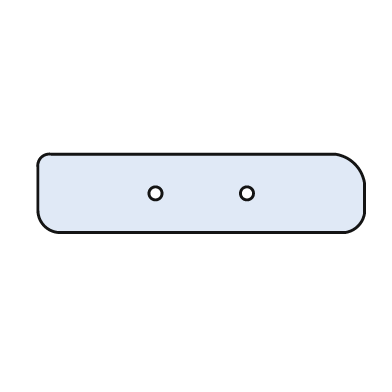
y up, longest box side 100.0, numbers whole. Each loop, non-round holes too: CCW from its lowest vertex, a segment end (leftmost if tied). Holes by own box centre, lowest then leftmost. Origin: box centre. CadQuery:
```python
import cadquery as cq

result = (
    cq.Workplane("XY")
    .moveTo(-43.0, -12.0)
    .lineTo(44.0, -12.0)
    .threePointArc((48.0, -10.0), (50.0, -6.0))
    .lineTo(50.0, 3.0)
    .threePointArc((47.0, 9.0), (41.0, 12.0))
    .lineTo(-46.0, 12.0)
    .threePointArc((-49.0, 11.0), (-50.0, 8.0))
    .lineTo(-50.0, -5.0)
    .threePointArc((-48.0, -10.0), (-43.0, -12.0))
    .close()
    .moveTo(-14.0, 0.0)
    .circle(2.0)
    .moveTo(14.0, 0.0)
    .circle(2.0)
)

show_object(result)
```